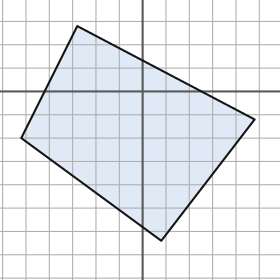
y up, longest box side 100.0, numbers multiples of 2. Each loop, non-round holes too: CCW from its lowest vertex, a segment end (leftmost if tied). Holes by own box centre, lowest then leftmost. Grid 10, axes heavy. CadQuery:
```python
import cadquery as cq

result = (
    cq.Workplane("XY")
    .moveTo(8.0, -64.0)
    .lineTo(48.0, -12.0)
    .lineTo(-28.0, 28.0)
    .lineTo(-52.0, -20.0)
    .close()
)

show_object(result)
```